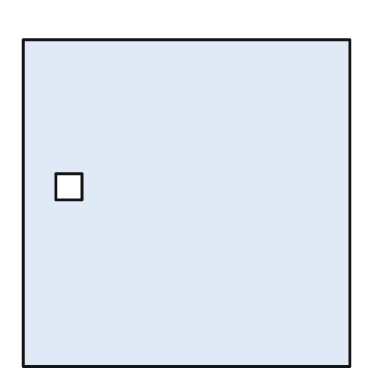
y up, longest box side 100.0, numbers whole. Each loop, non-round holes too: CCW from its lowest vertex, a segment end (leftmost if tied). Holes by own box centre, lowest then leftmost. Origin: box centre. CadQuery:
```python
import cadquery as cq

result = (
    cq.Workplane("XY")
    .moveTo(-50.0, -50.0)
    .lineTo(50.0, -50.0)
    .lineTo(50.0, 50.0)
    .lineTo(-50.0, 50.0)
    .close()
    .moveTo(-40.0, 1.0)
    .lineTo(-32.0, 1.0)
    .lineTo(-32.0, 9.0)
    .lineTo(-40.0, 9.0)
    .close()
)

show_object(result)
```